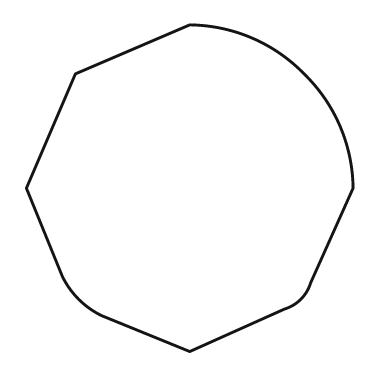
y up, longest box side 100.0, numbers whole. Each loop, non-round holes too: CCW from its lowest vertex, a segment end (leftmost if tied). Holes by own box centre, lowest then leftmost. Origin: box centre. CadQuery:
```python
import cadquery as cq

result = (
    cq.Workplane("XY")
    .moveTo(0.0, -50.0)
    .lineTo(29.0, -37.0)
    .threePointArc((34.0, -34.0), (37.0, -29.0))
    .lineTo(50.0, 0.0)
    .threePointArc((46.0, 19.0), (35.0, 35.0))
    .threePointArc((19.0, 46.0), (0.0, 50.0))
    .lineTo(-35.0, 35.0)
    .lineTo(-50.0, 0.0)
    .lineTo(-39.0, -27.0)
    .threePointArc((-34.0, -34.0), (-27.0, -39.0))
    .close()
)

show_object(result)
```